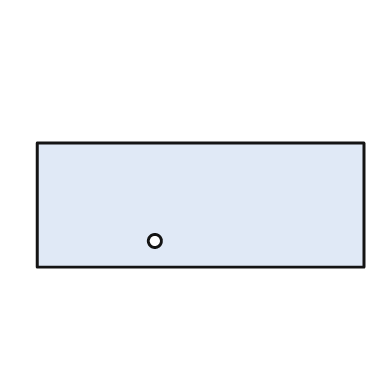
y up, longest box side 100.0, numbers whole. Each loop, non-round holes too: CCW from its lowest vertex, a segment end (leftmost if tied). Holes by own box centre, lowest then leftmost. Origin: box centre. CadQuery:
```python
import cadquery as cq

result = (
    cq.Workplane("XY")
    .moveTo(-50.0, -19.0)
    .lineTo(50.0, -19.0)
    .lineTo(50.0, 19.0)
    .lineTo(-50.0, 19.0)
    .close()
    .moveTo(-14.0, -11.0)
    .circle(2.0)
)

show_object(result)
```